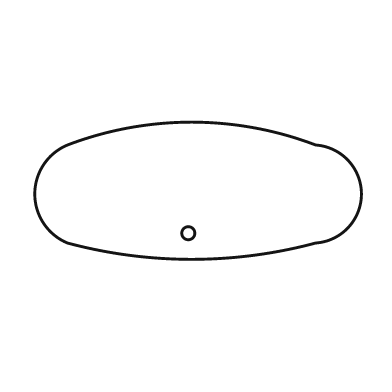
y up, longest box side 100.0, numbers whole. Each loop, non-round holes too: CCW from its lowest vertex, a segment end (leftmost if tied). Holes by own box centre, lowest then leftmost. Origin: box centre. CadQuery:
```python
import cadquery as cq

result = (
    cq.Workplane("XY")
    .moveTo(-40.0, -16.0)
    .threePointArc((-2.0, -21.0), (36.0, -16.0))
    .threePointArc((50.0, -1.0), (36.0, 14.0))
    .threePointArc((-2.0, 21.0), (-40.0, 14.0))
    .threePointArc((-50.0, -1.0), (-40.0, -16.0))
    .close()
    .moveTo(-3.0, -13.0)
    .circle(2.0)
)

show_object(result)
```